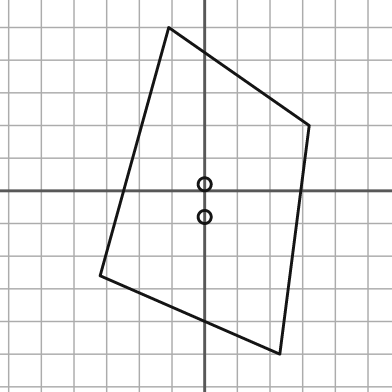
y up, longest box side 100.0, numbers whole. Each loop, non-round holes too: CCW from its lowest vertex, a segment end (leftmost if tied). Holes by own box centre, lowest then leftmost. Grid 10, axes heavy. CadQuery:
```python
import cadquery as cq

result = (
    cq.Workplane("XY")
    .moveTo(23.0, -50.0)
    .lineTo(32.0, 20.0)
    .lineTo(-11.0, 50.0)
    .lineTo(-32.0, -26.0)
    .close()
    .moveTo(0.0, -8.0)
    .circle(2.0)
    .moveTo(0.0, 2.0)
    .circle(2.0)
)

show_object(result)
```